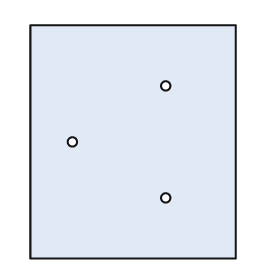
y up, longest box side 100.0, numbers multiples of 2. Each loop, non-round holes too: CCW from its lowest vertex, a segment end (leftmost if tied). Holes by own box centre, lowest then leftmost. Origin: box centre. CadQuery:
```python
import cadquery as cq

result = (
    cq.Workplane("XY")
    .moveTo(-44.0, -50.0)
    .lineTo(44.0, -50.0)
    .lineTo(44.0, 50.0)
    .lineTo(-44.0, 50.0)
    .close()
    .moveTo(14.0, -24.0)
    .circle(2.0)
    .moveTo(-26.0, 0.0)
    .circle(2.0)
    .moveTo(14.0, 24.0)
    .circle(2.0)
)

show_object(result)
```